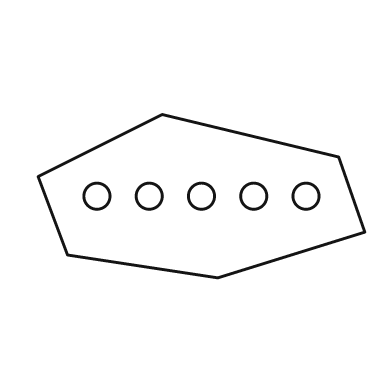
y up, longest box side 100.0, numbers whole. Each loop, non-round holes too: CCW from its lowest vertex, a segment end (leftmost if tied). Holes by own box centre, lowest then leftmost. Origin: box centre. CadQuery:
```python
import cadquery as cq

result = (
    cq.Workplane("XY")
    .moveTo(5.0, -25.0)
    .lineTo(50.0, -11.0)
    .lineTo(42.0, 12.0)
    .lineTo(-12.0, 25.0)
    .lineTo(-50.0, 6.0)
    .lineTo(-41.0, -18.0)
    .close()
    .moveTo(-32.0, 0.0)
    .circle(4.0)
    .moveTo(-16.0, 0.0)
    .circle(4.0)
    .moveTo(0.0, 0.0)
    .circle(4.0)
    .moveTo(16.0, 0.0)
    .circle(4.0)
    .moveTo(32.0, 0.0)
    .circle(4.0)
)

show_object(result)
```